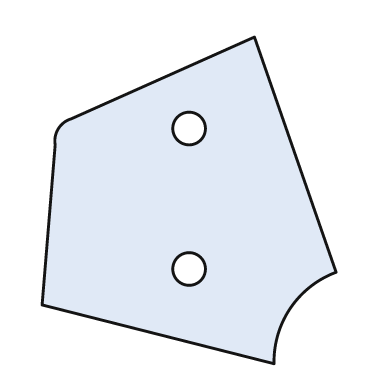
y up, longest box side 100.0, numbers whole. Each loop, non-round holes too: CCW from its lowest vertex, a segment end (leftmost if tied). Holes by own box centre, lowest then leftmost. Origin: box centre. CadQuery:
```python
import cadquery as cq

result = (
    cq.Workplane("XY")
    .moveTo(26.0, -50.0)
    .threePointArc((31.0, -33.0), (45.0, -22.0))
    .lineTo(20.0, 50.0)
    .lineTo(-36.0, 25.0)
    .threePointArc((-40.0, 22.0), (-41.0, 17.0))
    .lineTo(-45.0, -32.0)
    .close()
    .moveTo(0.0, -21.0)
    .circle(5.0)
    .moveTo(0.0, 22.0)
    .circle(5.0)
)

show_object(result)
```